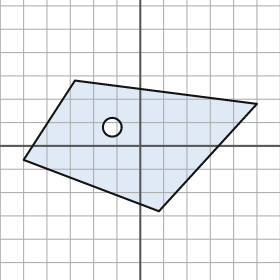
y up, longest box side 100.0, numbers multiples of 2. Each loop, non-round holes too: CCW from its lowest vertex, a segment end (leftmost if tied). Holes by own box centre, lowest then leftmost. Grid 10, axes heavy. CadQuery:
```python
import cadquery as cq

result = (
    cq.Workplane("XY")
    .moveTo(8.0, -28.0)
    .lineTo(50.0, 18.0)
    .lineTo(-28.0, 28.0)
    .lineTo(-50.0, -6.0)
    .close()
    .moveTo(-12.0, 8.0)
    .circle(4.0)
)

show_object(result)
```